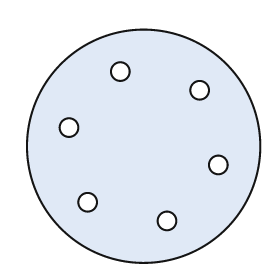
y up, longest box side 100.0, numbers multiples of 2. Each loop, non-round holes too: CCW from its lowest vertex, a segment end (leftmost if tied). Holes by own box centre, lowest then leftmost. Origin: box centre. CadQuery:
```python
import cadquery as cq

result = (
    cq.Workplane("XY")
    .moveTo(0.0, 0.0)
    .circle(50.0)
    .moveTo(10.0, -32.0)
    .circle(4.0)
    .moveTo(-24.0, -24.0)
    .circle(4.0)
    .moveTo(32.0, -8.0)
    .circle(4.0)
    .moveTo(-32.0, 8.0)
    .circle(4.0)
    .moveTo(24.0, 24.0)
    .circle(4.0)
    .moveTo(-10.0, 32.0)
    .circle(4.0)
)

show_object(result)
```